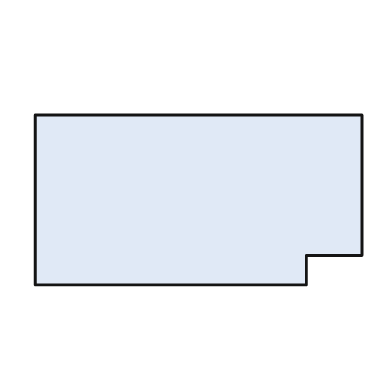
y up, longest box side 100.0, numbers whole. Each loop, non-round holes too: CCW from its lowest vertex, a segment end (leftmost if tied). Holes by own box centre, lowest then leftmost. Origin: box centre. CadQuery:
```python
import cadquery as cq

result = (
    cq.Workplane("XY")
    .moveTo(-50.0, -26.0)
    .lineTo(33.0, -26.0)
    .lineTo(33.0, -17.0)
    .lineTo(50.0, -17.0)
    .lineTo(50.0, 26.0)
    .lineTo(-50.0, 26.0)
    .close()
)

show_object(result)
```